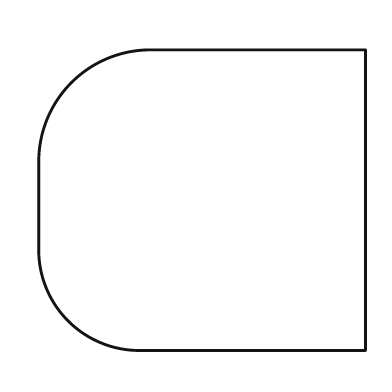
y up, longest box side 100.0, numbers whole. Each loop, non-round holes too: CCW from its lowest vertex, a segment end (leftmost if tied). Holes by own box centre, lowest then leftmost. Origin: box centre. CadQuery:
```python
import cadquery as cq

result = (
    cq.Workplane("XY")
    .moveTo(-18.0, -46.0)
    .lineTo(50.0, -46.0)
    .lineTo(50.0, 46.0)
    .lineTo(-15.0, 46.0)
    .threePointArc((-40.0, 36.0), (-50.0, 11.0))
    .lineTo(-50.0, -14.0)
    .threePointArc((-41.0, -37.0), (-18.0, -46.0))
    .close()
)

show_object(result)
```